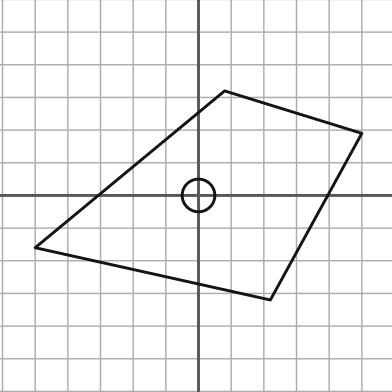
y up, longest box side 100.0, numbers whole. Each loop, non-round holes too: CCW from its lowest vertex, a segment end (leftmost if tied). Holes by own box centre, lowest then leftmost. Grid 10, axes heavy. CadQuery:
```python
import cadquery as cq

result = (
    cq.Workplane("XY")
    .moveTo(22.0, -32.0)
    .lineTo(50.0, 19.0)
    .lineTo(8.0, 32.0)
    .lineTo(-50.0, -16.0)
    .close()
    .moveTo(0.0, 0.0)
    .circle(5.0)
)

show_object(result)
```